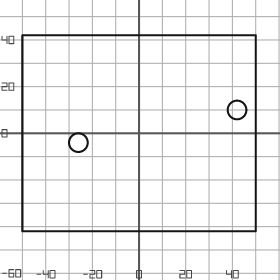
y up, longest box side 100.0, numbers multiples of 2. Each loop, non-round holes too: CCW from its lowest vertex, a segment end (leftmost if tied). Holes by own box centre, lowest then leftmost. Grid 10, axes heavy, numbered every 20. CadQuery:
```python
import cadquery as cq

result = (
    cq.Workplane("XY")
    .moveTo(-50.0, -42.0)
    .lineTo(50.0, -42.0)
    .lineTo(50.0, 42.0)
    .lineTo(-50.0, 42.0)
    .close()
    .moveTo(-26.0, -4.0)
    .circle(4.0)
    .moveTo(42.0, 10.0)
    .circle(4.0)
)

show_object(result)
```